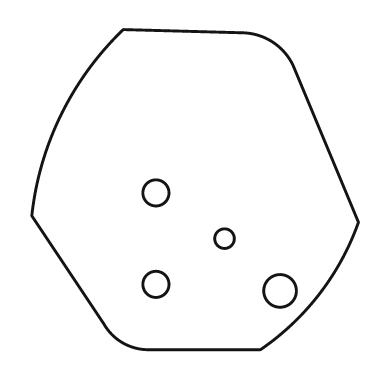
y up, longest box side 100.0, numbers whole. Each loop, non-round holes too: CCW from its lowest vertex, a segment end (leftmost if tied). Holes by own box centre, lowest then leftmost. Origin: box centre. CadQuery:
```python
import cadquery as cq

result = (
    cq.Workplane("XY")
    .moveTo(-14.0, -49.0)
    .lineTo(20.0, -49.0)
    .threePointArc((38.0, -32.0), (50.0, -10.0))
    .lineTo(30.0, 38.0)
    .threePointArc((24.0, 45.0), (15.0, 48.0))
    .lineTo(-22.0, 49.0)
    .threePointArc((-41.0, 23.0), (-50.0, -8.0))
    .lineTo(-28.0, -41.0)
    .threePointArc((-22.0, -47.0), (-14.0, -49.0))
    .close()
    .moveTo(26.0, -31.0)
    .circle(5.0)
    .moveTo(-12.0, -29.0)
    .circle(4.0)
    .moveTo(9.0, -15.0)
    .circle(3.0)
    .moveTo(-12.0, -1.0)
    .circle(4.0)
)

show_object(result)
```